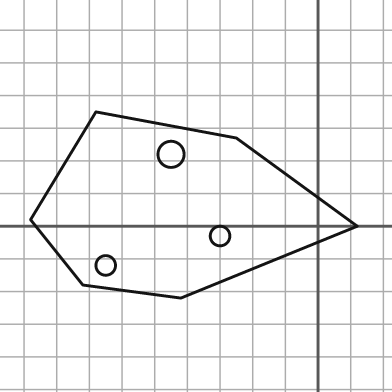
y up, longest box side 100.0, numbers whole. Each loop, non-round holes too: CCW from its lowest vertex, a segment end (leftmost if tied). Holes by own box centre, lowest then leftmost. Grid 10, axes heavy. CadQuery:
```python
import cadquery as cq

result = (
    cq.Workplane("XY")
    .moveTo(-42.0, -22.0)
    .lineTo(12.0, 0.0)
    .lineTo(-25.0, 27.0)
    .lineTo(-68.0, 35.0)
    .lineTo(-88.0, 2.0)
    .lineTo(-72.0, -18.0)
    .close()
    .moveTo(-65.0, -12.0)
    .circle(3.0)
    .moveTo(-30.0, -3.0)
    .circle(3.0)
    .moveTo(-45.0, 22.0)
    .circle(4.0)
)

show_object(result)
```